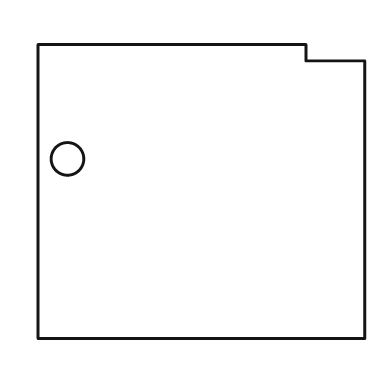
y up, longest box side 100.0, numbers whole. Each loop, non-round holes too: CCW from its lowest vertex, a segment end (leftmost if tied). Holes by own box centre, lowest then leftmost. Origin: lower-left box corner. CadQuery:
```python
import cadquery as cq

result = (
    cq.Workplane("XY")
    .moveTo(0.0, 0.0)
    .lineTo(100.0, 0.0)
    .lineTo(100.0, 85.0)
    .lineTo(82.0, 85.0)
    .lineTo(82.0, 90.0)
    .lineTo(0.0, 90.0)
    .close()
    .moveTo(9.0, 55.0)
    .circle(5.0)
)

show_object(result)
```